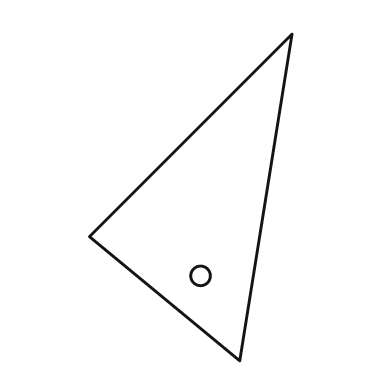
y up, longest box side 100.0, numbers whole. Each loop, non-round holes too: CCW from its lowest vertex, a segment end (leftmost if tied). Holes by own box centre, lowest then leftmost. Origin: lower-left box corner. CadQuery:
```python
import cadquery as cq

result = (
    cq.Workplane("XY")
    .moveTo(46.0, 0.0)
    .lineTo(62.0, 100.0)
    .lineTo(0.0, 38.0)
    .close()
    .moveTo(34.0, 26.0)
    .circle(3.0)
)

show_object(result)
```